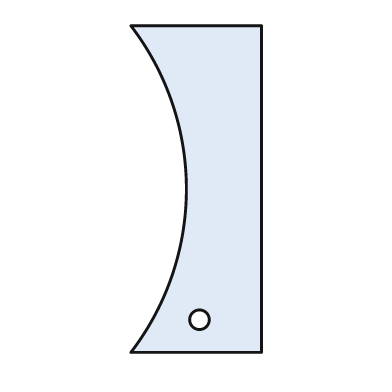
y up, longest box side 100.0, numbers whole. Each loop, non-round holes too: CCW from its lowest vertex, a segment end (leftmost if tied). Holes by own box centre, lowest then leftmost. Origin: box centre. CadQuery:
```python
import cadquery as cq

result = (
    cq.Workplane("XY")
    .moveTo(-20.0, -50.0)
    .lineTo(20.0, -50.0)
    .lineTo(20.0, 50.0)
    .lineTo(-20.0, 50.0)
    .threePointArc((-3.0, 0.0), (-20.0, -50.0))
    .close()
    .moveTo(1.0, -40.0)
    .circle(3.0)
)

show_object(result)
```